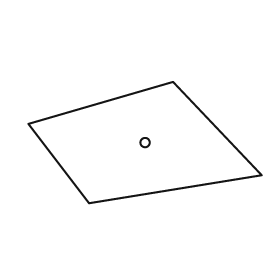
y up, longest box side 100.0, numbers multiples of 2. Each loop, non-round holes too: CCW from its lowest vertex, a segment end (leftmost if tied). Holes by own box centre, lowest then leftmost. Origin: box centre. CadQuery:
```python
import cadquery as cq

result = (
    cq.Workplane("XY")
    .moveTo(-24.0, -26.0)
    .lineTo(50.0, -14.0)
    .lineTo(12.0, 26.0)
    .lineTo(-50.0, 8.0)
    .close()
    .moveTo(0.0, 0.0)
    .circle(2.0)
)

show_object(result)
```